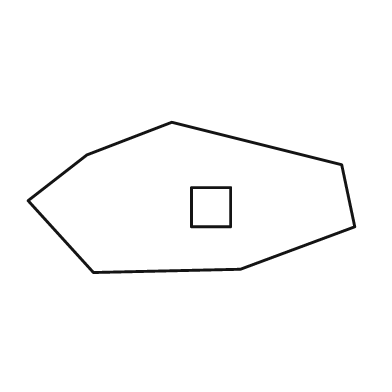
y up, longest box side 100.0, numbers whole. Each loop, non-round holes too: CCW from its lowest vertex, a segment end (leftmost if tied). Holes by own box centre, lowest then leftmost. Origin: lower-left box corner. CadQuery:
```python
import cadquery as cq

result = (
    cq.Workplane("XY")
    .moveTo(20.0, 0.0)
    .lineTo(65.0, 1.0)
    .lineTo(100.0, 14.0)
    .lineTo(96.0, 33.0)
    .lineTo(44.0, 46.0)
    .lineTo(18.0, 36.0)
    .lineTo(0.0, 22.0)
    .close()
    .moveTo(50.0, 14.0)
    .lineTo(62.0, 14.0)
    .lineTo(62.0, 26.0)
    .lineTo(50.0, 26.0)
    .close()
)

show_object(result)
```